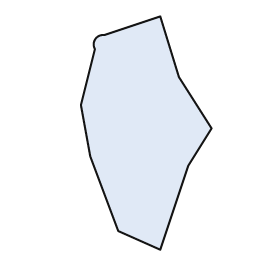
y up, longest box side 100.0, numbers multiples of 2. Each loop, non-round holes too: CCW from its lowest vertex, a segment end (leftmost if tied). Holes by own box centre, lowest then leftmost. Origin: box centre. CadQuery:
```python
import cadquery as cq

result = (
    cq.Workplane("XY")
    .moveTo(6.0, -50.0)
    .lineTo(18.0, -14.0)
    .lineTo(28.0, 2.0)
    .lineTo(14.0, 24.0)
    .lineTo(6.0, 50.0)
    .lineTo(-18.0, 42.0)
    .threePointArc((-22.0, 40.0), (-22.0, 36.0))
    .lineTo(-28.0, 12.0)
    .lineTo(-24.0, -10.0)
    .lineTo(-12.0, -42.0)
    .close()
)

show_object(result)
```